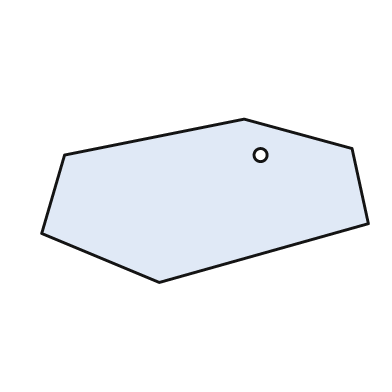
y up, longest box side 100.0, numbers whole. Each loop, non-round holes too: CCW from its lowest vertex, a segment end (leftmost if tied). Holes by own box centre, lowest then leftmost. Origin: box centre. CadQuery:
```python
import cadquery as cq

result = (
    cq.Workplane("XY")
    .moveTo(-14.0, -25.0)
    .lineTo(50.0, -7.0)
    .lineTo(45.0, 16.0)
    .lineTo(12.0, 25.0)
    .lineTo(-43.0, 14.0)
    .lineTo(-50.0, -10.0)
    .close()
    .moveTo(17.0, 14.0)
    .circle(2.0)
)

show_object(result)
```